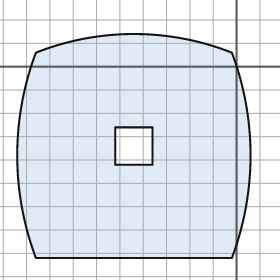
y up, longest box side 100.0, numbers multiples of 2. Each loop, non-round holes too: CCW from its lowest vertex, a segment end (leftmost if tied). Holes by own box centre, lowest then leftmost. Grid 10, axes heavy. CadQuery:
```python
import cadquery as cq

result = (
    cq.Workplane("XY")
    .moveTo(-86.0, -82.0)
    .lineTo(-2.0, -82.0)
    .threePointArc((6.0, -38.0), (-2.0, 6.0))
    .threePointArc((-44.0, 14.0), (-86.0, 6.0))
    .threePointArc((-94.0, -38.0), (-86.0, -82.0))
    .close()
    .moveTo(-52.0, -42.0)
    .lineTo(-36.0, -42.0)
    .lineTo(-36.0, -26.0)
    .lineTo(-52.0, -26.0)
    .close()
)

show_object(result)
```